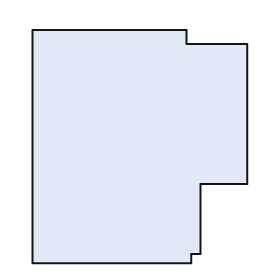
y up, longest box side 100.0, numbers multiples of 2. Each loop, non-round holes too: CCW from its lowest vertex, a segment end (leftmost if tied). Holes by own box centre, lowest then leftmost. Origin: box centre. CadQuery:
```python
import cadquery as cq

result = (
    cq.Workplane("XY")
    .moveTo(-46.0, -50.0)
    .lineTo(22.0, -50.0)
    .lineTo(22.0, -46.0)
    .lineTo(26.0, -46.0)
    .lineTo(26.0, -16.0)
    .lineTo(46.0, -16.0)
    .lineTo(46.0, 44.0)
    .lineTo(20.0, 44.0)
    .lineTo(20.0, 50.0)
    .lineTo(-46.0, 50.0)
    .close()
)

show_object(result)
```